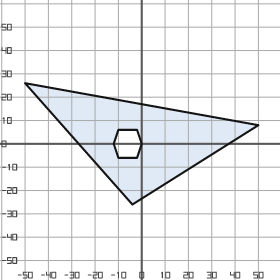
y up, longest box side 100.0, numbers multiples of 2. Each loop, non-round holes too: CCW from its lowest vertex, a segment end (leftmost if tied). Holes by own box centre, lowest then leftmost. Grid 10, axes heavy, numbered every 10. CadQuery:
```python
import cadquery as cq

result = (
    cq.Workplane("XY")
    .moveTo(-4.0, -26.0)
    .lineTo(50.0, 8.0)
    .lineTo(-50.0, 26.0)
    .close()
    .moveTo(-10.0, -6.0)
    .lineTo(-2.0, -6.0)
    .lineTo(0.0, 0.0)
    .lineTo(-2.0, 6.0)
    .lineTo(-10.0, 6.0)
    .lineTo(-12.0, 0.0)
    .close()
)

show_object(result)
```